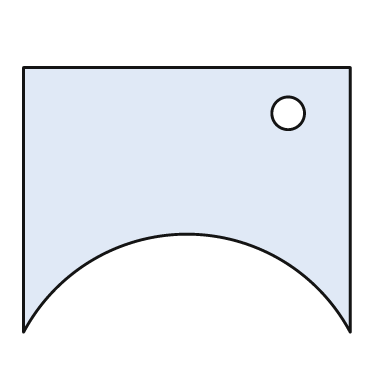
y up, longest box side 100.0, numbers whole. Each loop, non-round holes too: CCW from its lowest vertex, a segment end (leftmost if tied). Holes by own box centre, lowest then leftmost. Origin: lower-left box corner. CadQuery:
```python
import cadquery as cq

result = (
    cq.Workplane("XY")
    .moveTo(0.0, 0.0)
    .threePointArc((50.0, 30.0), (100.0, 0.0))
    .lineTo(100.0, 81.0)
    .lineTo(0.0, 81.0)
    .close()
    .moveTo(81.0, 67.0)
    .circle(5.0)
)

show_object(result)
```